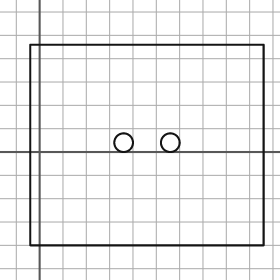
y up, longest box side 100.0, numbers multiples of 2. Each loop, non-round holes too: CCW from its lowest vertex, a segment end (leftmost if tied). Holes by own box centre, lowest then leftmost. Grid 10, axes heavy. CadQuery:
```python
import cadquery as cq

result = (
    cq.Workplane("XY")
    .moveTo(-4.0, -40.0)
    .lineTo(96.0, -40.0)
    .lineTo(96.0, 46.0)
    .lineTo(-4.0, 46.0)
    .close()
    .moveTo(36.0, 4.0)
    .circle(4.0)
    .moveTo(56.0, 4.0)
    .circle(4.0)
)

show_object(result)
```